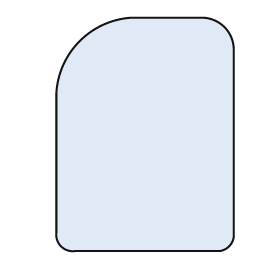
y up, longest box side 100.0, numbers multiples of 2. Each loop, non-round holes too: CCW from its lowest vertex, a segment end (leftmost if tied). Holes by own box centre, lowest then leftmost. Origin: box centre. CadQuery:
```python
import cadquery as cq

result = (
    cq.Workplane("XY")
    .moveTo(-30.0, -50.0)
    .lineTo(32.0, -50.0)
    .threePointArc((36.0, -48.0), (38.0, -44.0))
    .lineTo(38.0, 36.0)
    .threePointArc((34.0, 46.0), (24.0, 50.0))
    .lineTo(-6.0, 50.0)
    .threePointArc((-28.0, 40.0), (-38.0, 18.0))
    .lineTo(-38.0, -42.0)
    .threePointArc((-36.0, -48.0), (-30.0, -50.0))
    .close()
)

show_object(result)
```